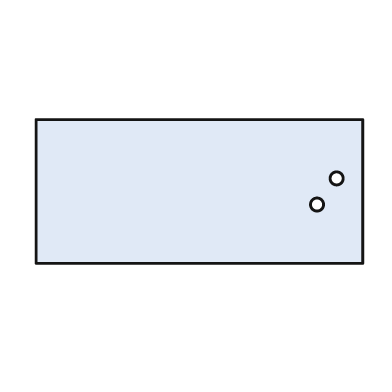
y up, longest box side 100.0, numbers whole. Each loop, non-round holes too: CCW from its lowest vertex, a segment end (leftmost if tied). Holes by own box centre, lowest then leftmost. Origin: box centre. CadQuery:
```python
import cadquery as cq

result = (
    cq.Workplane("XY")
    .moveTo(-50.0, -22.0)
    .lineTo(50.0, -22.0)
    .lineTo(50.0, 22.0)
    .lineTo(-50.0, 22.0)
    .close()
    .moveTo(36.0, -4.0)
    .circle(2.0)
    .moveTo(42.0, 4.0)
    .circle(2.0)
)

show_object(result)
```